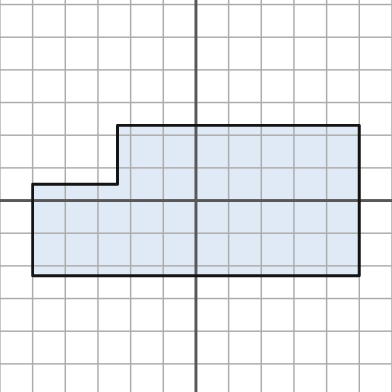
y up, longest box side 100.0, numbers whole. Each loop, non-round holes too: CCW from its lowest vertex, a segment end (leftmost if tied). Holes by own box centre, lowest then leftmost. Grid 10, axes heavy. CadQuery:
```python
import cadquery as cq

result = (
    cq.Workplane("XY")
    .moveTo(-50.0, -23.0)
    .lineTo(50.0, -23.0)
    .lineTo(50.0, 23.0)
    .lineTo(-24.0, 23.0)
    .lineTo(-24.0, 5.0)
    .lineTo(-50.0, 5.0)
    .close()
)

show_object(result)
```